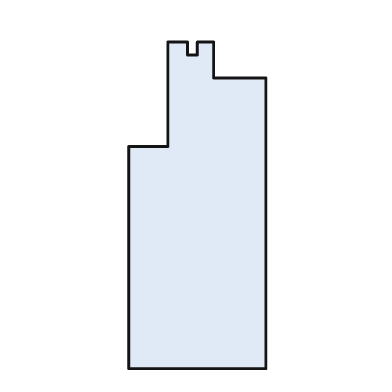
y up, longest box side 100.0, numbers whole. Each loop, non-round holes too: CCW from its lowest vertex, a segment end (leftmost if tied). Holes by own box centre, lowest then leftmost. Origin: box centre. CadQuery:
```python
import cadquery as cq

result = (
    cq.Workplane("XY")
    .moveTo(-21.0, -50.0)
    .lineTo(21.0, -50.0)
    .lineTo(21.0, 39.0)
    .lineTo(5.0, 39.0)
    .lineTo(5.0, 50.0)
    .lineTo(0.0, 50.0)
    .lineTo(0.0, 46.0)
    .lineTo(-3.0, 46.0)
    .lineTo(-3.0, 50.0)
    .lineTo(-9.0, 50.0)
    .lineTo(-9.0, 18.0)
    .lineTo(-21.0, 18.0)
    .close()
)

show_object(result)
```